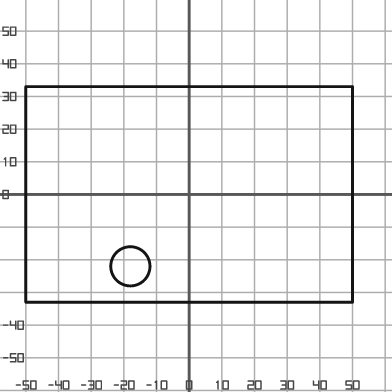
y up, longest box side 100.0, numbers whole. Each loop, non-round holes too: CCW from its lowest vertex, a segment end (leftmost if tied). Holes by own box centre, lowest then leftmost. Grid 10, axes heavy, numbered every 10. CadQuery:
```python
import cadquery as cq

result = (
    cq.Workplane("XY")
    .moveTo(-50.0, -33.0)
    .lineTo(50.0, -33.0)
    .lineTo(50.0, 33.0)
    .lineTo(-50.0, 33.0)
    .close()
    .moveTo(-18.0, -22.0)
    .circle(6.0)
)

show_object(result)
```